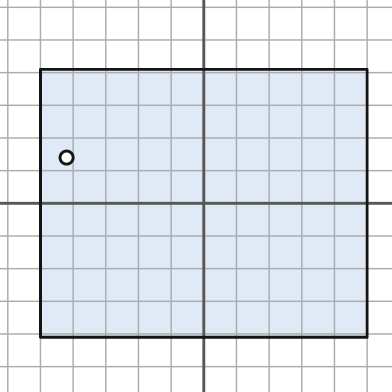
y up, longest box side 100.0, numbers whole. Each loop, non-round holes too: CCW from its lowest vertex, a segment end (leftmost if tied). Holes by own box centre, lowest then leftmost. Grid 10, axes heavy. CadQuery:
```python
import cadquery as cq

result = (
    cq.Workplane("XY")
    .moveTo(-50.0, -41.0)
    .lineTo(50.0, -41.0)
    .lineTo(50.0, 41.0)
    .lineTo(-50.0, 41.0)
    .close()
    .moveTo(-42.0, 14.0)
    .circle(2.0)
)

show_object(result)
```